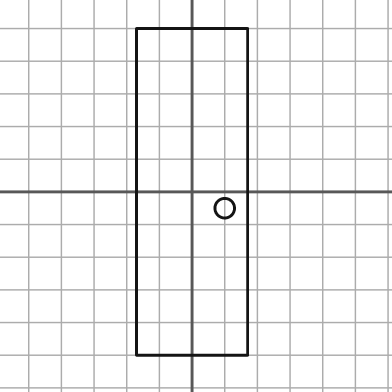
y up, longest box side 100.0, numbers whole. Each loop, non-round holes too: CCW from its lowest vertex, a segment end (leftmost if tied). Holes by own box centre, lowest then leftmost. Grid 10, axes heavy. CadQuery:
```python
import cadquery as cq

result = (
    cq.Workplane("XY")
    .moveTo(-17.0, -50.0)
    .lineTo(17.0, -50.0)
    .lineTo(17.0, 50.0)
    .lineTo(-17.0, 50.0)
    .close()
    .moveTo(10.0, -5.0)
    .circle(3.0)
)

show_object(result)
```